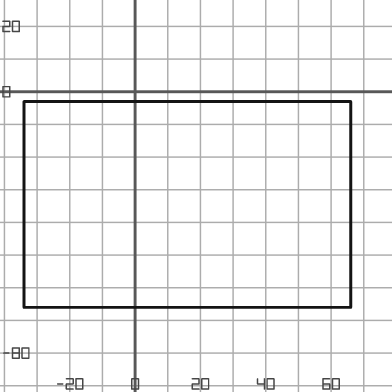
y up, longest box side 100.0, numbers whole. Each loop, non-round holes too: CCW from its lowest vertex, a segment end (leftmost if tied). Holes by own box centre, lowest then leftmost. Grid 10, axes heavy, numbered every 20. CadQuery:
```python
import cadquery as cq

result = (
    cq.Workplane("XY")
    .moveTo(-34.0, -66.0)
    .lineTo(66.0, -66.0)
    .lineTo(66.0, -3.0)
    .lineTo(-34.0, -3.0)
    .close()
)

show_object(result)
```